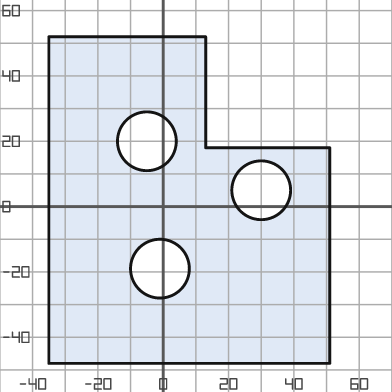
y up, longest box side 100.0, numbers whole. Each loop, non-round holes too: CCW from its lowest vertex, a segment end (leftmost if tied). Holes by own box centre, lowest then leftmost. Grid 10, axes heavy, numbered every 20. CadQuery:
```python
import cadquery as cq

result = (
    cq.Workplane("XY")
    .moveTo(-35.0, -48.0)
    .lineTo(51.0, -48.0)
    .lineTo(51.0, 18.0)
    .lineTo(13.0, 18.0)
    .lineTo(13.0, 52.0)
    .lineTo(-35.0, 52.0)
    .close()
    .moveTo(-1.0, -19.0)
    .circle(9.0)
    .moveTo(30.0, 5.0)
    .circle(9.0)
    .moveTo(-5.0, 20.0)
    .circle(9.0)
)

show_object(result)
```